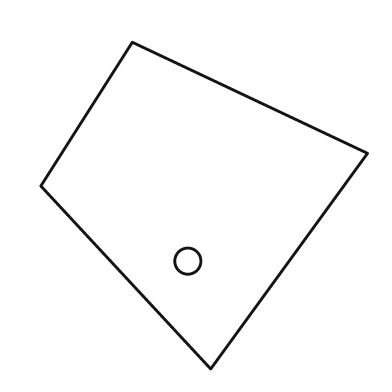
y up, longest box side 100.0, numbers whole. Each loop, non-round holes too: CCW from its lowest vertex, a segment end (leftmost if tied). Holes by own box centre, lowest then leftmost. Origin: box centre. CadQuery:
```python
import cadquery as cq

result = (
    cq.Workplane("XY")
    .moveTo(2.0, -50.0)
    .lineTo(50.0, 16.0)
    .lineTo(-22.0, 50.0)
    .lineTo(-50.0, 6.0)
    .close()
    .moveTo(-5.0, -17.0)
    .circle(4.0)
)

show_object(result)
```